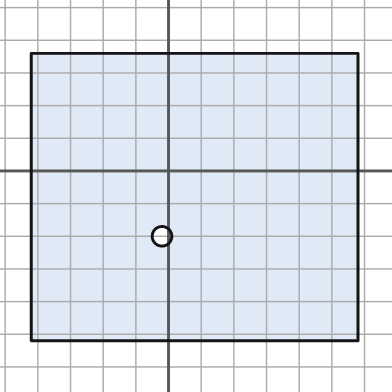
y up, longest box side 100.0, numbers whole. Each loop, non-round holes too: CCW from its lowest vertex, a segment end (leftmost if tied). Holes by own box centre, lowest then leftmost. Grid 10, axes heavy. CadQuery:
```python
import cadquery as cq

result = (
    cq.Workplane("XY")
    .moveTo(-42.0, -52.0)
    .lineTo(58.0, -52.0)
    .lineTo(58.0, 36.0)
    .lineTo(-42.0, 36.0)
    .close()
    .moveTo(-2.0, -20.0)
    .circle(3.0)
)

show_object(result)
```